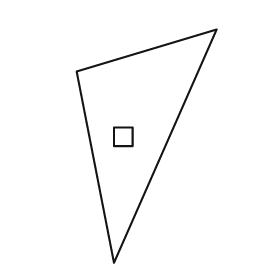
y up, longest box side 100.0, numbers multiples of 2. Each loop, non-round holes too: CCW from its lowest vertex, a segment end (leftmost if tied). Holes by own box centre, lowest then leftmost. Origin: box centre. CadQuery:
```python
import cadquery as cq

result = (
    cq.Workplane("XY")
    .moveTo(-14.0, -50.0)
    .lineTo(30.0, 50.0)
    .lineTo(-30.0, 32.0)
    .close()
    .moveTo(-14.0, 0.0)
    .lineTo(-6.0, 0.0)
    .lineTo(-6.0, 8.0)
    .lineTo(-14.0, 8.0)
    .close()
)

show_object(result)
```